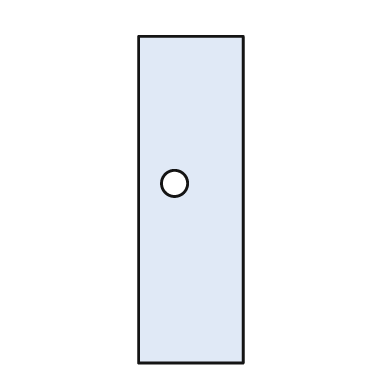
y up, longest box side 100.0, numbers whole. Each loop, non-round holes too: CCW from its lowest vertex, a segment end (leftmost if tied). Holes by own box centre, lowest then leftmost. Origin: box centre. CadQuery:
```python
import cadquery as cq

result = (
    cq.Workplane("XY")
    .moveTo(-16.0, -50.0)
    .lineTo(16.0, -50.0)
    .lineTo(16.0, 50.0)
    .lineTo(-16.0, 50.0)
    .close()
    .moveTo(-5.0, 5.0)
    .circle(4.0)
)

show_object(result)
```